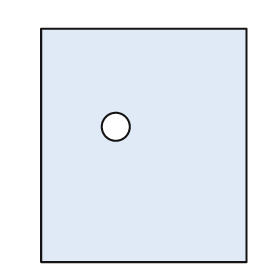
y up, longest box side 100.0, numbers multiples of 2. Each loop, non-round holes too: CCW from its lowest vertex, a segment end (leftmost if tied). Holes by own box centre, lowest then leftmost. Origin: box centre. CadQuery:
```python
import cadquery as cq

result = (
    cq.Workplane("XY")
    .moveTo(-44.0, -50.0)
    .lineTo(44.0, -50.0)
    .lineTo(44.0, 50.0)
    .lineTo(-44.0, 50.0)
    .close()
    .moveTo(-12.0, 8.0)
    .circle(6.0)
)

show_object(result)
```